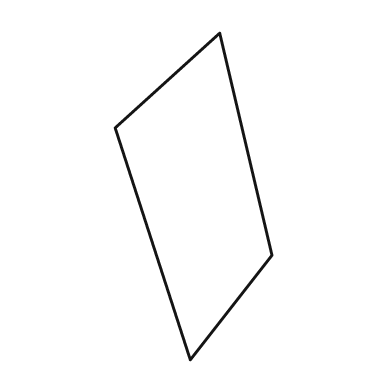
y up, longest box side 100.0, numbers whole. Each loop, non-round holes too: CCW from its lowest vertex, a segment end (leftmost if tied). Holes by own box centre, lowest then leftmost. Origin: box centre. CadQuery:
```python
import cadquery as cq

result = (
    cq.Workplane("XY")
    .moveTo(-1.0, -50.0)
    .lineTo(24.0, -18.0)
    .lineTo(8.0, 50.0)
    .lineTo(-24.0, 21.0)
    .close()
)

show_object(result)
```